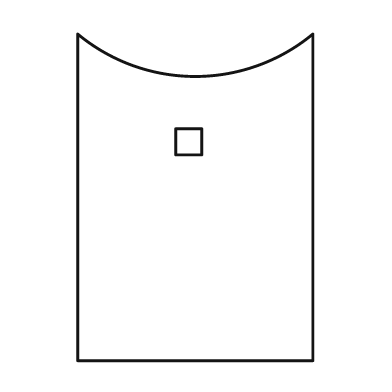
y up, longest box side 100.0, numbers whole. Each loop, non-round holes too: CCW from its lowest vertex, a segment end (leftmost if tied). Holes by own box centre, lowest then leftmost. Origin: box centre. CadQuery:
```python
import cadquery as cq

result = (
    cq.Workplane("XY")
    .moveTo(-36.0, -50.0)
    .lineTo(36.0, -50.0)
    .lineTo(36.0, 50.0)
    .threePointArc((0.0, 37.0), (-36.0, 50.0))
    .close()
    .moveTo(-6.0, 13.0)
    .lineTo(2.0, 13.0)
    .lineTo(2.0, 21.0)
    .lineTo(-6.0, 21.0)
    .close()
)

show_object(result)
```